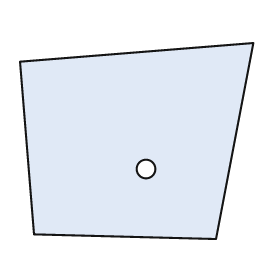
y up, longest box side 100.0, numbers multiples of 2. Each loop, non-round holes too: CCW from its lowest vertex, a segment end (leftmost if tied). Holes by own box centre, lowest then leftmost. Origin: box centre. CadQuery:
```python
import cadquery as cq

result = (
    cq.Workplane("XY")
    .moveTo(34.0, -42.0)
    .lineTo(50.0, 42.0)
    .lineTo(-50.0, 34.0)
    .lineTo(-44.0, -40.0)
    .close()
    .moveTo(4.0, -12.0)
    .circle(4.0)
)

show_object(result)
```